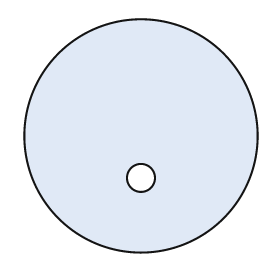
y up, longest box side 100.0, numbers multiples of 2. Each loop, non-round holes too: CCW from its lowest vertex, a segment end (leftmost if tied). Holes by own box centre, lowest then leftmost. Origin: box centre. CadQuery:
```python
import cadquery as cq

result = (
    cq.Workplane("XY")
    .moveTo(0.0, 0.0)
    .circle(50.0)
    .moveTo(0.0, -18.0)
    .circle(6.0)
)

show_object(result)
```